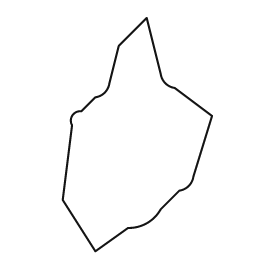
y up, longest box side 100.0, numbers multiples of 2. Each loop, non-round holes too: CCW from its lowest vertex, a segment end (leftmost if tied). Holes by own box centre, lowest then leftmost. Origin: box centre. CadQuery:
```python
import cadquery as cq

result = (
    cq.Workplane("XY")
    .moveTo(-18.0, -50.0)
    .lineTo(-4.0, -40.0)
    .threePointArc((4.0, -38.0), (10.0, -32.0))
    .lineTo(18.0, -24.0)
    .threePointArc((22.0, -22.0), (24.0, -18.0))
    .lineTo(32.0, 8.0)
    .lineTo(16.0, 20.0)
    .threePointArc((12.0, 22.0), (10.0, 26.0))
    .lineTo(4.0, 50.0)
    .lineTo(-8.0, 38.0)
    .lineTo(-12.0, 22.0)
    .threePointArc((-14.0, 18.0), (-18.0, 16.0))
    .lineTo(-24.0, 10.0)
    .threePointArc((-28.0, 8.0), (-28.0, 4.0))
    .lineTo(-32.0, -28.0)
    .close()
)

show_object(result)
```